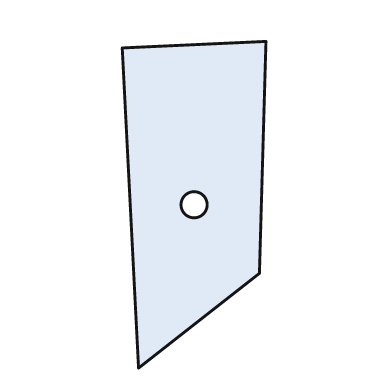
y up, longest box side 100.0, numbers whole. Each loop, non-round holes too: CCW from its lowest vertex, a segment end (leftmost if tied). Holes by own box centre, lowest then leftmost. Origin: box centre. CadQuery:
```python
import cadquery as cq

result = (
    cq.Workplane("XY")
    .moveTo(-17.0, -50.0)
    .lineTo(20.0, -21.0)
    .lineTo(22.0, 50.0)
    .lineTo(-22.0, 48.0)
    .close()
    .moveTo(0.0, 0.0)
    .circle(4.0)
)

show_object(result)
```